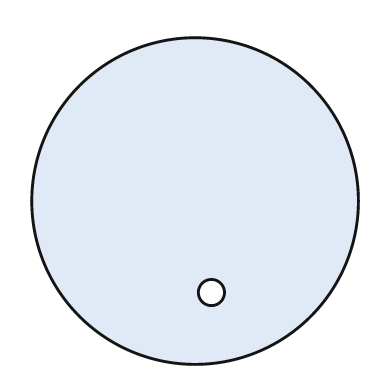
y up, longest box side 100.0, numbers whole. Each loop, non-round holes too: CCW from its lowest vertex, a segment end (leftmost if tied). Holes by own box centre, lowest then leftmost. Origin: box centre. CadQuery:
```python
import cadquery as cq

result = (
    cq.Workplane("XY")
    .moveTo(0.0, 0.0)
    .circle(50.0)
    .moveTo(5.0, -28.0)
    .circle(4.0)
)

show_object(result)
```